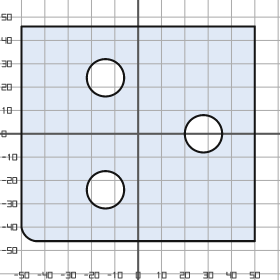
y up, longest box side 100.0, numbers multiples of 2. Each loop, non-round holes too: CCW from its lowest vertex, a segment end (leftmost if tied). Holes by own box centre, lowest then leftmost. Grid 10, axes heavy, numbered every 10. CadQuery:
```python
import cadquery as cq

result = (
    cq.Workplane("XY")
    .moveTo(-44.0, -46.0)
    .lineTo(50.0, -46.0)
    .lineTo(50.0, 46.0)
    .lineTo(-50.0, 46.0)
    .lineTo(-50.0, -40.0)
    .threePointArc((-48.0, -44.0), (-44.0, -46.0))
    .close()
    .moveTo(-14.0, -24.0)
    .circle(8.0)
    .moveTo(28.0, 0.0)
    .circle(8.0)
    .moveTo(-14.0, 24.0)
    .circle(8.0)
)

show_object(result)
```